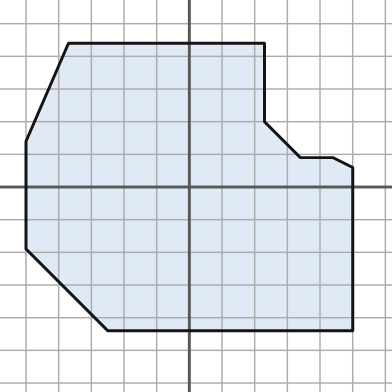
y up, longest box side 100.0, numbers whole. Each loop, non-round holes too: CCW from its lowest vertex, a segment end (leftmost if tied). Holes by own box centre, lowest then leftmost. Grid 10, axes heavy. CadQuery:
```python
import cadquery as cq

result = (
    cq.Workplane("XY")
    .moveTo(-25.0, -44.0)
    .lineTo(50.0, -44.0)
    .lineTo(50.0, 6.0)
    .lineTo(44.0, 9.0)
    .lineTo(34.0, 9.0)
    .lineTo(23.0, 20.0)
    .lineTo(23.0, 44.0)
    .lineTo(-37.0, 44.0)
    .lineTo(-50.0, 14.0)
    .lineTo(-50.0, -19.0)
    .close()
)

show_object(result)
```